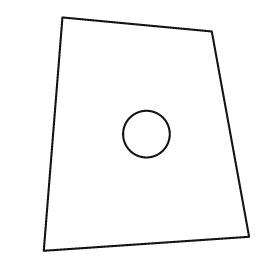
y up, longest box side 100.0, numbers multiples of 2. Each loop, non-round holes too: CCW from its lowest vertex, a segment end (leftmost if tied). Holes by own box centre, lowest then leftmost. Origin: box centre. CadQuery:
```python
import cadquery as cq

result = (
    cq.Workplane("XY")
    .moveTo(-44.0, -50.0)
    .lineTo(44.0, -44.0)
    .lineTo(28.0, 44.0)
    .lineTo(-36.0, 50.0)
    .close()
    .moveTo(0.0, 0.0)
    .circle(10.0)
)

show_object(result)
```